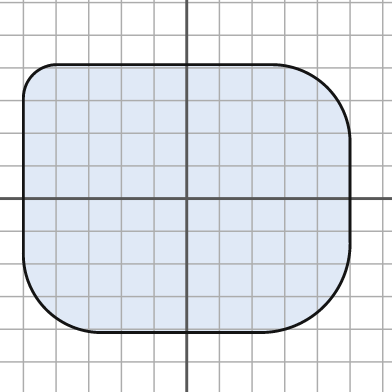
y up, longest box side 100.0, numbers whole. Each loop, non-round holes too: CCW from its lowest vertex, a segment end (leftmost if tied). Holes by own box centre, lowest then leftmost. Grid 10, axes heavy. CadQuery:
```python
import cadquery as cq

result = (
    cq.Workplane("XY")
    .moveTo(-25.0, -41.0)
    .lineTo(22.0, -41.0)
    .threePointArc((42.0, -33.0), (50.0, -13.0))
    .lineTo(50.0, 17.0)
    .threePointArc((43.0, 34.0), (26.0, 41.0))
    .lineTo(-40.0, 41.0)
    .threePointArc((-47.0, 38.0), (-50.0, 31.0))
    .lineTo(-50.0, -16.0)
    .threePointArc((-43.0, -34.0), (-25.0, -41.0))
    .close()
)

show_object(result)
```